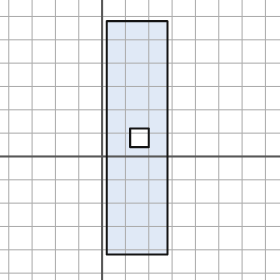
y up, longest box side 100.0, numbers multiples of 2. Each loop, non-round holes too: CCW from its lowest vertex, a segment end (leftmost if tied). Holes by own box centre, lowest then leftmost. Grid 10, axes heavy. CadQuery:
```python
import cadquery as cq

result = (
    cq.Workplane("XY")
    .moveTo(2.0, -42.0)
    .lineTo(28.0, -42.0)
    .lineTo(28.0, 58.0)
    .lineTo(2.0, 58.0)
    .close()
    .moveTo(12.0, 4.0)
    .lineTo(20.0, 4.0)
    .lineTo(20.0, 12.0)
    .lineTo(12.0, 12.0)
    .close()
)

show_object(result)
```